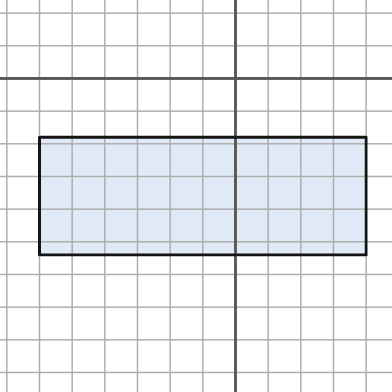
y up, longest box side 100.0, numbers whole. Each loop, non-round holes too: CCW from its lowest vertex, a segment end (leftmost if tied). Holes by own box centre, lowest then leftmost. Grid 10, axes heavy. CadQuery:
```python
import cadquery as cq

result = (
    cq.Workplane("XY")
    .moveTo(-60.0, -54.0)
    .lineTo(40.0, -54.0)
    .lineTo(40.0, -18.0)
    .lineTo(-60.0, -18.0)
    .close()
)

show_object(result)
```